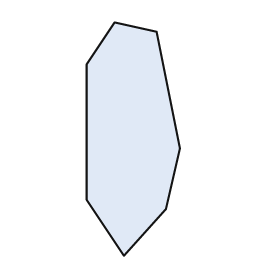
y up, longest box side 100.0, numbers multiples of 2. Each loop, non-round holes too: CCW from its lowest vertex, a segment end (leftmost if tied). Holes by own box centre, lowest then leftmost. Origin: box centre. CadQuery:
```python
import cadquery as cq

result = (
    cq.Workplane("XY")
    .moveTo(-4.0, -50.0)
    .lineTo(14.0, -30.0)
    .lineTo(20.0, -4.0)
    .lineTo(10.0, 46.0)
    .lineTo(-8.0, 50.0)
    .lineTo(-20.0, 32.0)
    .lineTo(-20.0, -26.0)
    .close()
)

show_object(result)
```